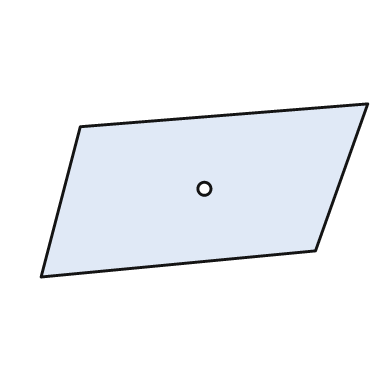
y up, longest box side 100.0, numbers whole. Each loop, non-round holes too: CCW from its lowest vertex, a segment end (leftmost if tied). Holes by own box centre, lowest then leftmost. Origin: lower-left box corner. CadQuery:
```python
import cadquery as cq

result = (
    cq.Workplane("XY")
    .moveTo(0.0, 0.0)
    .lineTo(84.0, 8.0)
    .lineTo(100.0, 53.0)
    .lineTo(12.0, 46.0)
    .close()
    .moveTo(50.0, 27.0)
    .circle(2.0)
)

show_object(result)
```